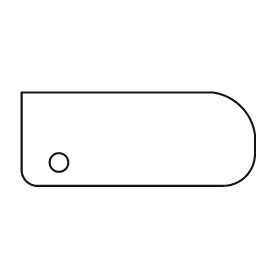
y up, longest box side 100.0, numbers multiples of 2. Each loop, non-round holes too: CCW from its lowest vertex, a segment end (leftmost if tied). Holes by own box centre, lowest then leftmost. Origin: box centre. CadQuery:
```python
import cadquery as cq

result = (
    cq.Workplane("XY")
    .moveTo(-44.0, -20.0)
    .lineTo(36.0, -20.0)
    .threePointArc((46.0, -16.0), (50.0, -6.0))
    .lineTo(50.0, 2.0)
    .threePointArc((44.0, 14.0), (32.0, 20.0))
    .lineTo(-50.0, 20.0)
    .lineTo(-50.0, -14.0)
    .threePointArc((-48.0, -18.0), (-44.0, -20.0))
    .close()
    .moveTo(-34.0, -10.0)
    .circle(4.0)
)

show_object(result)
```